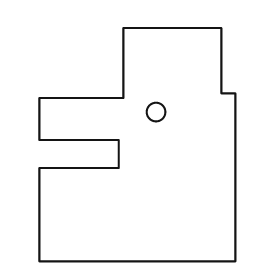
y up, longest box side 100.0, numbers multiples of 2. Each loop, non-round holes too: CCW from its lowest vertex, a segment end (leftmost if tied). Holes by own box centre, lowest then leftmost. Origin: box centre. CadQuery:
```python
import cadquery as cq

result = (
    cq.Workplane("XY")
    .moveTo(-42.0, -50.0)
    .lineTo(42.0, -50.0)
    .lineTo(42.0, 22.0)
    .lineTo(36.0, 22.0)
    .lineTo(36.0, 50.0)
    .lineTo(-6.0, 50.0)
    .lineTo(-6.0, 20.0)
    .lineTo(-42.0, 20.0)
    .lineTo(-42.0, 2.0)
    .lineTo(-8.0, 2.0)
    .lineTo(-8.0, -10.0)
    .lineTo(-42.0, -10.0)
    .close()
    .moveTo(8.0, 14.0)
    .circle(4.0)
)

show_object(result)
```